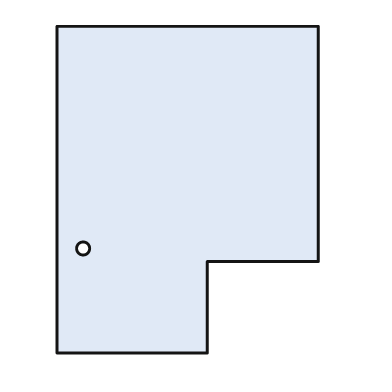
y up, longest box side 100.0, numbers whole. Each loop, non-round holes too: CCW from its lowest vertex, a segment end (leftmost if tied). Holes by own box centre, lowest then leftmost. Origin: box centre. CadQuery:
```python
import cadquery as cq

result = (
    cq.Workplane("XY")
    .moveTo(-40.0, -50.0)
    .lineTo(6.0, -50.0)
    .lineTo(6.0, -22.0)
    .lineTo(40.0, -22.0)
    .lineTo(40.0, 50.0)
    .lineTo(-40.0, 50.0)
    .close()
    .moveTo(-32.0, -18.0)
    .circle(2.0)
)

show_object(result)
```